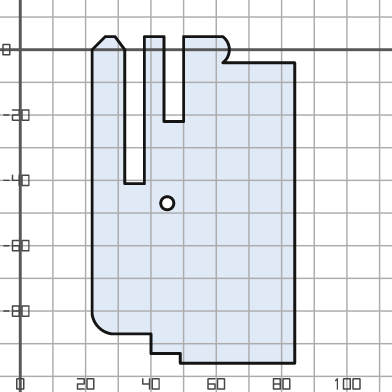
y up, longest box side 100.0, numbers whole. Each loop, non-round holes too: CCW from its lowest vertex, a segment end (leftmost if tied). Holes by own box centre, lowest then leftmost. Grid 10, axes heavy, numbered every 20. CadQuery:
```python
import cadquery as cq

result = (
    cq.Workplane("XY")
    .moveTo(49.0, -96.0)
    .lineTo(84.0, -96.0)
    .lineTo(84.0, -4.0)
    .lineTo(62.0, -4.0)
    .threePointArc((64.0, 0.0), (62.0, 4.0))
    .lineTo(50.0, 4.0)
    .lineTo(50.0, -22.0)
    .lineTo(44.0, -22.0)
    .lineTo(44.0, 4.0)
    .lineTo(38.0, 4.0)
    .lineTo(38.0, -41.0)
    .lineTo(32.0, -41.0)
    .lineTo(32.0, 0.0)
    .lineTo(29.0, 4.0)
    .lineTo(26.0, 4.0)
    .lineTo(22.0, 0.0)
    .lineTo(22.0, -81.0)
    .threePointArc((24.0, -85.0), (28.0, -87.0))
    .lineTo(40.0, -87.0)
    .lineTo(40.0, -93.0)
    .lineTo(49.0, -93.0)
    .close()
    .moveTo(45.0, -47.0)
    .circle(2.0)
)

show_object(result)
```